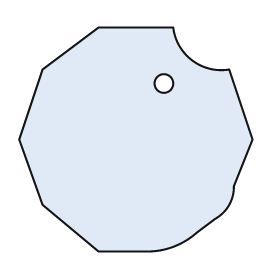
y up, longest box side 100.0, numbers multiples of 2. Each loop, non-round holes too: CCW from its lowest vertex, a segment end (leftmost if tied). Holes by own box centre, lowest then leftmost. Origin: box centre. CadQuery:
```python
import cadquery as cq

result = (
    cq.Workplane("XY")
    .moveTo(-16.0, -48.0)
    .lineTo(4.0, -48.0)
    .threePointArc((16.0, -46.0), (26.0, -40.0))
    .lineTo(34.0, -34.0)
    .threePointArc((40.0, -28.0), (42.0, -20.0))
    .lineTo(50.0, 0.0)
    .lineTo(40.0, 30.0)
    .threePointArc((24.0, 34.0), (16.0, 48.0))
    .lineTo(-16.0, 48.0)
    .lineTo(-40.0, 30.0)
    .lineTo(-50.0, 0.0)
    .lineTo(-40.0, -28.0)
    .close()
    .moveTo(12.0, 24.0)
    .circle(4.0)
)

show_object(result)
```